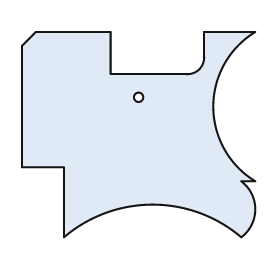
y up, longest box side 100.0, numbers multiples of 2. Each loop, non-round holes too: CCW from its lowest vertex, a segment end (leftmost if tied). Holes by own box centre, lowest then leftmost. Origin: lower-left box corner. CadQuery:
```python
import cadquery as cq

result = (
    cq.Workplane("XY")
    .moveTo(18.0, 0.0)
    .threePointArc((56.0, 14.0), (94.0, 0.0))
    .threePointArc((100.0, 12.0), (94.0, 24.0))
    .lineTo(100.0, 24.0)
    .threePointArc((82.0, 56.0), (100.0, 88.0))
    .lineTo(78.0, 88.0)
    .lineTo(78.0, 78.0)
    .threePointArc((76.0, 72.0), (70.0, 70.0))
    .lineTo(38.0, 70.0)
    .lineTo(38.0, 88.0)
    .lineTo(6.0, 88.0)
    .lineTo(0.0, 82.0)
    .lineTo(0.0, 30.0)
    .lineTo(18.0, 30.0)
    .close()
    .moveTo(50.0, 60.0)
    .circle(2.0)
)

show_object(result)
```